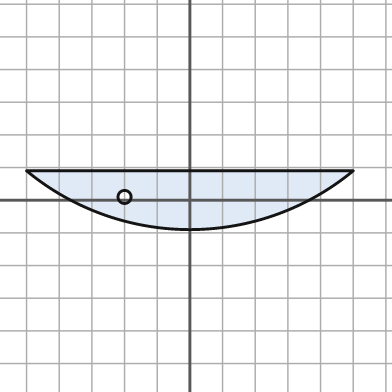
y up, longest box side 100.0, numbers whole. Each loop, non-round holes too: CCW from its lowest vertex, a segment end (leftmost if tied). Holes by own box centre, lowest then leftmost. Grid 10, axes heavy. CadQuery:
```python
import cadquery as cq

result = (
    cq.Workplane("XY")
    .moveTo(-50.0, 9.0)
    .threePointArc((0.0, -9.0), (50.0, 9.0))
    .close()
    .moveTo(-20.0, 1.0)
    .circle(2.0)
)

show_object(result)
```